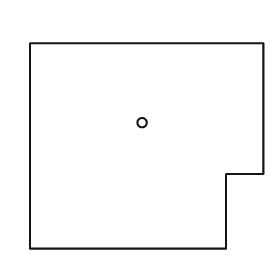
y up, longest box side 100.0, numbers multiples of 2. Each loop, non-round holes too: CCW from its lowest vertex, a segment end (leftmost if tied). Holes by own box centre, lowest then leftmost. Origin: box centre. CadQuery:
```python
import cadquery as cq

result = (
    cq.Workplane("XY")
    .moveTo(-50.0, -44.0)
    .lineTo(34.0, -44.0)
    .lineTo(34.0, -12.0)
    .lineTo(50.0, -12.0)
    .lineTo(50.0, 44.0)
    .lineTo(-50.0, 44.0)
    .close()
    .moveTo(-2.0, 10.0)
    .circle(2.0)
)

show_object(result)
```